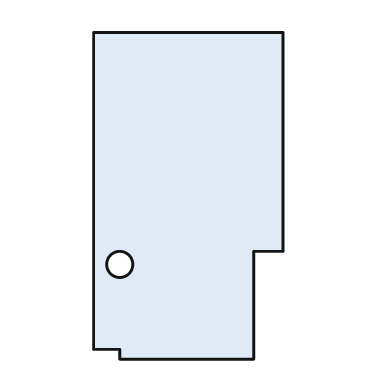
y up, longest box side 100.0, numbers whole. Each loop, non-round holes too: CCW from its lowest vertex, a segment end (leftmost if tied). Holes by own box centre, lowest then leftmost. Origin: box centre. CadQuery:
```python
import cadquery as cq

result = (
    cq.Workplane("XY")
    .moveTo(-21.0, -50.0)
    .lineTo(20.0, -50.0)
    .lineTo(20.0, -17.0)
    .lineTo(29.0, -17.0)
    .lineTo(29.0, 50.0)
    .lineTo(-29.0, 50.0)
    .lineTo(-29.0, -47.0)
    .lineTo(-21.0, -47.0)
    .close()
    .moveTo(-21.0, -21.0)
    .circle(4.0)
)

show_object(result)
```